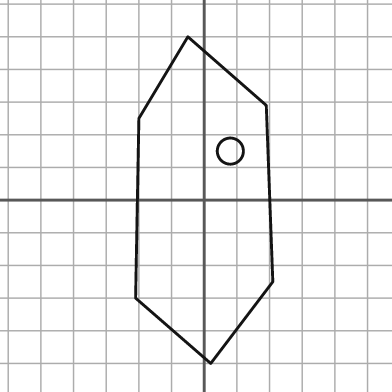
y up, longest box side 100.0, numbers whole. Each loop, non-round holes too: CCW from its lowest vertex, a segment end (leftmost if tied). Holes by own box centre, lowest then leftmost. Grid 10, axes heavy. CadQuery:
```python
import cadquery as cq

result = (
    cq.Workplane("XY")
    .moveTo(2.0, -50.0)
    .lineTo(21.0, -25.0)
    .lineTo(19.0, 29.0)
    .lineTo(-5.0, 50.0)
    .lineTo(-20.0, 25.0)
    .lineTo(-21.0, -30.0)
    .close()
    .moveTo(8.0, 15.0)
    .circle(4.0)
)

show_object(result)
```